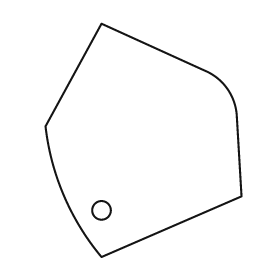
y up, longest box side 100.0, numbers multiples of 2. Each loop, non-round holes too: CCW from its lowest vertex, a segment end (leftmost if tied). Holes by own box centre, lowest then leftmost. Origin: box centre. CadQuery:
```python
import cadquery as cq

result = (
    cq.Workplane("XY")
    .moveTo(-18.0, -50.0)
    .lineTo(42.0, -24.0)
    .lineTo(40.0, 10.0)
    .threePointArc((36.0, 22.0), (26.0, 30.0))
    .lineTo(-18.0, 50.0)
    .lineTo(-42.0, 6.0)
    .threePointArc((-34.0, -24.0), (-18.0, -50.0))
    .close()
    .moveTo(-18.0, -30.0)
    .circle(4.0)
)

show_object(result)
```